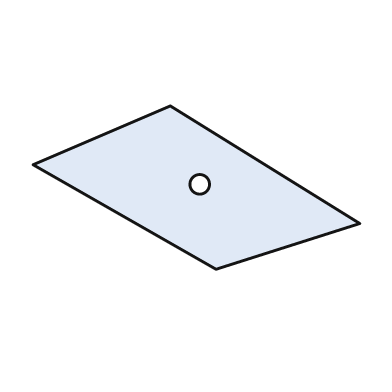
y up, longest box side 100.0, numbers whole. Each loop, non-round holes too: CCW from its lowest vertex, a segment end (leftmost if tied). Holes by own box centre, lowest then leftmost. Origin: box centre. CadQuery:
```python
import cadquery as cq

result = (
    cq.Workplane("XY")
    .moveTo(6.0, -25.0)
    .lineTo(50.0, -11.0)
    .lineTo(-8.0, 25.0)
    .lineTo(-50.0, 7.0)
    .close()
    .moveTo(1.0, 1.0)
    .circle(3.0)
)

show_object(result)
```